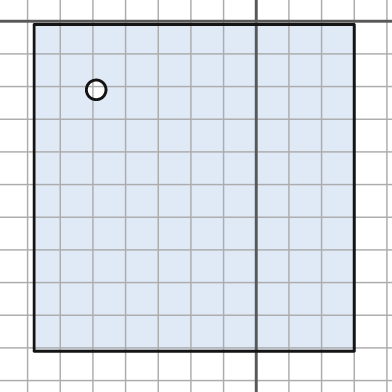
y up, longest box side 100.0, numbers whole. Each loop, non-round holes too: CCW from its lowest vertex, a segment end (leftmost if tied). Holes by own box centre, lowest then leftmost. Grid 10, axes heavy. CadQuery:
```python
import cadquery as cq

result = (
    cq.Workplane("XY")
    .moveTo(-68.0, -101.0)
    .lineTo(30.0, -101.0)
    .lineTo(30.0, -1.0)
    .lineTo(-68.0, -1.0)
    .close()
    .moveTo(-49.0, -21.0)
    .circle(3.0)
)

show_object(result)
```